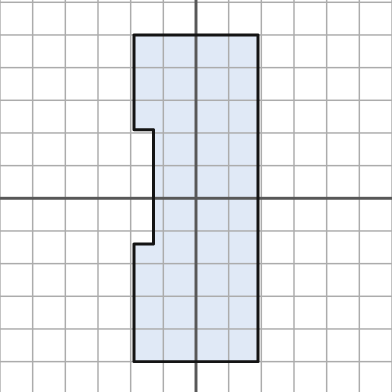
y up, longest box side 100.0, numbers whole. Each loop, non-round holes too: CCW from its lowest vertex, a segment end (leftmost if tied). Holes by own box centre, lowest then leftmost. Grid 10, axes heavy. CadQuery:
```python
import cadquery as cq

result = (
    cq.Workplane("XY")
    .moveTo(-19.0, -50.0)
    .lineTo(19.0, -50.0)
    .lineTo(19.0, 50.0)
    .lineTo(-19.0, 50.0)
    .lineTo(-19.0, 21.0)
    .lineTo(-13.0, 21.0)
    .lineTo(-13.0, -14.0)
    .lineTo(-19.0, -14.0)
    .close()
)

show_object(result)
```